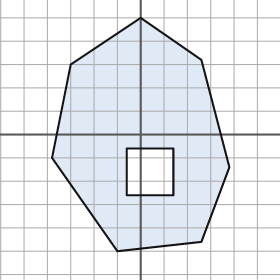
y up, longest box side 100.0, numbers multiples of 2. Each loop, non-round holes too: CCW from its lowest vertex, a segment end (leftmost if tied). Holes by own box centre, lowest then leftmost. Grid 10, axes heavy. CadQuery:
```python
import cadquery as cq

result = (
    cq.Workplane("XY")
    .moveTo(-10.0, -50.0)
    .lineTo(26.0, -46.0)
    .lineTo(38.0, -14.0)
    .lineTo(26.0, 32.0)
    .lineTo(0.0, 50.0)
    .lineTo(-30.0, 30.0)
    .lineTo(-38.0, -10.0)
    .close()
    .moveTo(-6.0, -26.0)
    .lineTo(14.0, -26.0)
    .lineTo(14.0, -6.0)
    .lineTo(-6.0, -6.0)
    .close()
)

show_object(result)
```